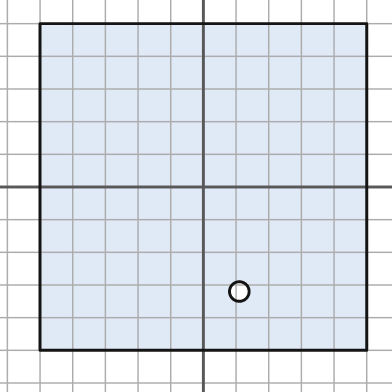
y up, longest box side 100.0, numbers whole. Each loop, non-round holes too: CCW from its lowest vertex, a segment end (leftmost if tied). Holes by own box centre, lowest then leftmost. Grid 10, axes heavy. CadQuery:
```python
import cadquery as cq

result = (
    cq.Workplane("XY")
    .moveTo(-50.0, -50.0)
    .lineTo(50.0, -50.0)
    .lineTo(50.0, 50.0)
    .lineTo(-50.0, 50.0)
    .close()
    .moveTo(11.0, -32.0)
    .circle(3.0)
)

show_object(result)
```